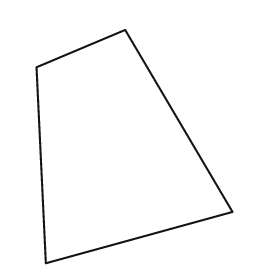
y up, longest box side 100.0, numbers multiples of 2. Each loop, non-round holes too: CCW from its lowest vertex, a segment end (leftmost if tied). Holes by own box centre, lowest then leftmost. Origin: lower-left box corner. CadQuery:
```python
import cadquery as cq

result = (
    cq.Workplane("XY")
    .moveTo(4.0, 0.0)
    .lineTo(84.0, 22.0)
    .lineTo(38.0, 100.0)
    .lineTo(0.0, 84.0)
    .close()
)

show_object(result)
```